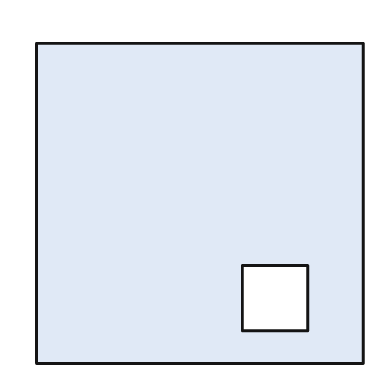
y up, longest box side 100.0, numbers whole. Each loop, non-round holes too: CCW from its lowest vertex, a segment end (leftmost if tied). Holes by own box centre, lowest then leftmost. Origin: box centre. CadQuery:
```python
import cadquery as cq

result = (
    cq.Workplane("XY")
    .moveTo(-50.0, -49.0)
    .lineTo(50.0, -49.0)
    .lineTo(50.0, 49.0)
    .lineTo(-50.0, 49.0)
    .close()
    .moveTo(13.0, -39.0)
    .lineTo(33.0, -39.0)
    .lineTo(33.0, -19.0)
    .lineTo(13.0, -19.0)
    .close()
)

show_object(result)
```